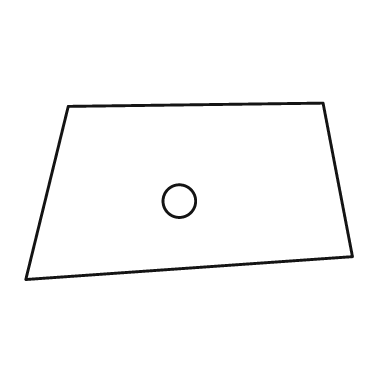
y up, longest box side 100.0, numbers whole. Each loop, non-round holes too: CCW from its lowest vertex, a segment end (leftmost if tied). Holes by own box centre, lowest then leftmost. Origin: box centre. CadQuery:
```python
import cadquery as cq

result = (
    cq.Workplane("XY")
    .moveTo(-50.0, -27.0)
    .lineTo(50.0, -20.0)
    .lineTo(41.0, 27.0)
    .lineTo(-37.0, 26.0)
    .close()
    .moveTo(-3.0, -3.0)
    .circle(5.0)
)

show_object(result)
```